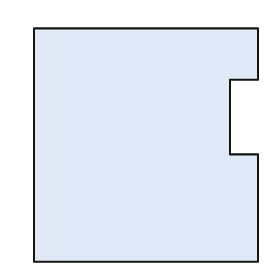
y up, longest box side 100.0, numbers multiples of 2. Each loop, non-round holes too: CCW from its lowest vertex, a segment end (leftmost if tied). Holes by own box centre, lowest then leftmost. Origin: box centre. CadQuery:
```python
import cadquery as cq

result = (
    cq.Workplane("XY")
    .moveTo(-48.0, -50.0)
    .lineTo(48.0, -50.0)
    .lineTo(48.0, -4.0)
    .lineTo(36.0, -4.0)
    .lineTo(36.0, 28.0)
    .lineTo(48.0, 28.0)
    .lineTo(48.0, 50.0)
    .lineTo(-48.0, 50.0)
    .close()
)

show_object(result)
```